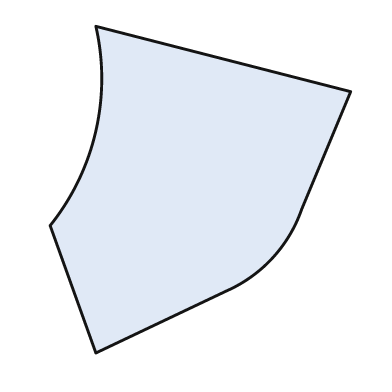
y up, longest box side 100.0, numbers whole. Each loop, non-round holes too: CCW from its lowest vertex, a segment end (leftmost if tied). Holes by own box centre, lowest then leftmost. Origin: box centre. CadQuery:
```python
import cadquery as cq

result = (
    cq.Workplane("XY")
    .moveTo(-32.0, -50.0)
    .lineTo(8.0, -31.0)
    .threePointArc((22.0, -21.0), (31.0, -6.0))
    .lineTo(46.0, 30.0)
    .lineTo(-32.0, 50.0)
    .threePointArc((-32.0, 18.0), (-46.0, -11.0))
    .close()
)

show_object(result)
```